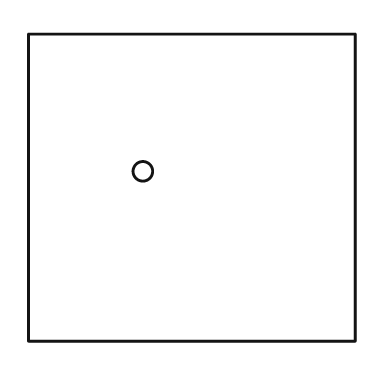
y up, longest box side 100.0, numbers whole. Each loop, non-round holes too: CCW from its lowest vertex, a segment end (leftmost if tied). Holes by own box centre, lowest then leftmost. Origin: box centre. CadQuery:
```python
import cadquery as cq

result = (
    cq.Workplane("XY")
    .moveTo(-50.0, -47.0)
    .lineTo(50.0, -47.0)
    .lineTo(50.0, 47.0)
    .lineTo(-50.0, 47.0)
    .close()
    .moveTo(-15.0, 5.0)
    .circle(3.0)
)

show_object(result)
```